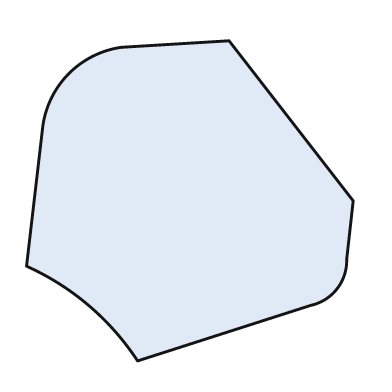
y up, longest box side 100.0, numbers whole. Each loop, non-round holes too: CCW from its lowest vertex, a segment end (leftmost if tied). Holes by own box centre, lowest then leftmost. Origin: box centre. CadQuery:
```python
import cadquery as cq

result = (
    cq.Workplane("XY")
    .moveTo(-16.0, -49.0)
    .lineTo(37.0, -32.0)
    .threePointArc((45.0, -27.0), (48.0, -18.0))
    .lineTo(50.0, 0.0)
    .lineTo(12.0, 49.0)
    .lineTo(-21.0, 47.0)
    .threePointArc((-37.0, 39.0), (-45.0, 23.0))
    .lineTo(-50.0, -20.0)
    .threePointArc((-31.0, -32.0), (-16.0, -49.0))
    .close()
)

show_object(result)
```